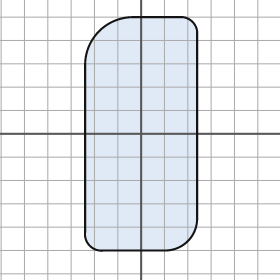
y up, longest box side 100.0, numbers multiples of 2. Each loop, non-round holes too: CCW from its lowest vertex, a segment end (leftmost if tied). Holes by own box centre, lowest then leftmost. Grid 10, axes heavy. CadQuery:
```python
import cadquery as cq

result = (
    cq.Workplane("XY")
    .moveTo(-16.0, -50.0)
    .lineTo(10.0, -50.0)
    .threePointArc((20.0, -46.0), (24.0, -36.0))
    .lineTo(24.0, 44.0)
    .threePointArc((22.0, 48.0), (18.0, 50.0))
    .lineTo(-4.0, 50.0)
    .threePointArc((-18.0, 44.0), (-24.0, 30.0))
    .lineTo(-24.0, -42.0)
    .threePointArc((-22.0, -48.0), (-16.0, -50.0))
    .close()
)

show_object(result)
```